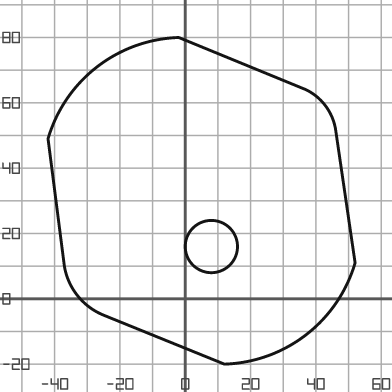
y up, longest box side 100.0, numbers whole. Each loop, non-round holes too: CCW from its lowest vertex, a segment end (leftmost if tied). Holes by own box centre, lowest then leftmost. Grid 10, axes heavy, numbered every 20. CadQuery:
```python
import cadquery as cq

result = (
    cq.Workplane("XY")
    .moveTo(12.0, -20.0)
    .threePointArc((37.0, -11.0), (52.0, 11.0))
    .lineTo(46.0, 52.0)
    .threePointArc((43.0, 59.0), (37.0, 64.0))
    .lineTo(-2.0, 80.0)
    .threePointArc((-27.0, 71.0), (-42.0, 49.0))
    .lineTo(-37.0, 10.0)
    .threePointArc((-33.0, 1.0), (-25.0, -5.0))
    .close()
    .moveTo(8.0, 16.0)
    .circle(8.0)
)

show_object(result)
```